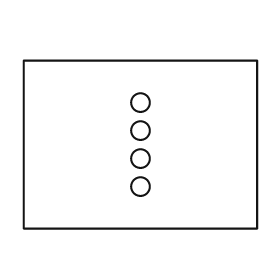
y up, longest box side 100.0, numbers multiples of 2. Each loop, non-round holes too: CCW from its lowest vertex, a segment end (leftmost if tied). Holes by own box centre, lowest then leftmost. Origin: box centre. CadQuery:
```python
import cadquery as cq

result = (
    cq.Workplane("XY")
    .moveTo(-50.0, -36.0)
    .lineTo(50.0, -36.0)
    .lineTo(50.0, 36.0)
    .lineTo(-50.0, 36.0)
    .close()
    .moveTo(0.0, -18.0)
    .circle(4.0)
    .moveTo(0.0, -6.0)
    .circle(4.0)
    .moveTo(0.0, 6.0)
    .circle(4.0)
    .moveTo(0.0, 18.0)
    .circle(4.0)
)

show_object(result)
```